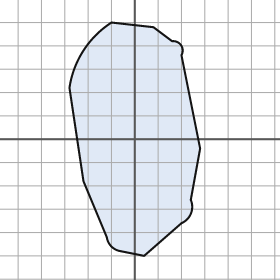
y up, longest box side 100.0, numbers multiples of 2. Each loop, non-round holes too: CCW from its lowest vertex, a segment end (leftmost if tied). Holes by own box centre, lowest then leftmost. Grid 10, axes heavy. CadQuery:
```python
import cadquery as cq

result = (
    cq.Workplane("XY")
    .moveTo(4.0, -50.0)
    .lineTo(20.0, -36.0)
    .threePointArc((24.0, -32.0), (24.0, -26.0))
    .lineTo(28.0, -4.0)
    .lineTo(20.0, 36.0)
    .threePointArc((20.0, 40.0), (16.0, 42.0))
    .lineTo(8.0, 48.0)
    .lineTo(-10.0, 50.0)
    .threePointArc((-22.0, 38.0), (-28.0, 22.0))
    .lineTo(-22.0, -18.0)
    .lineTo(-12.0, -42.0)
    .threePointArc((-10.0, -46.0), (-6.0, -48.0))
    .close()
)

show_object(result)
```